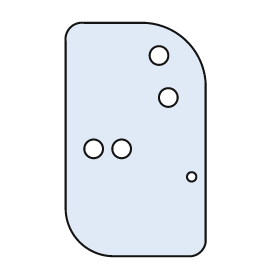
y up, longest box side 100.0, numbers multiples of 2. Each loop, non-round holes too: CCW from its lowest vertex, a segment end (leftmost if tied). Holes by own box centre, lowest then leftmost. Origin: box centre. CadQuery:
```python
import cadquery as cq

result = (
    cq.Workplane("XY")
    .moveTo(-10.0, -50.0)
    .lineTo(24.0, -50.0)
    .threePointArc((28.0, -48.0), (30.0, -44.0))
    .lineTo(30.0, 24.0)
    .threePointArc((22.0, 42.0), (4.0, 50.0))
    .lineTo(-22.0, 50.0)
    .threePointArc((-28.0, 48.0), (-30.0, 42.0))
    .lineTo(-30.0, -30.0)
    .threePointArc((-24.0, -44.0), (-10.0, -50.0))
    .close()
    .moveTo(24.0, -16.0)
    .circle(2.0)
    .moveTo(-18.0, -4.0)
    .circle(4.0)
    .moveTo(-6.0, -4.0)
    .circle(4.0)
    .moveTo(14.0, 18.0)
    .circle(4.0)
    .moveTo(10.0, 36.0)
    .circle(4.0)
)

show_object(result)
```